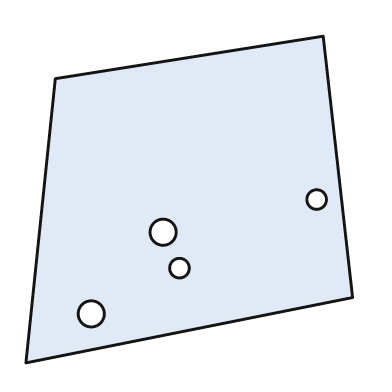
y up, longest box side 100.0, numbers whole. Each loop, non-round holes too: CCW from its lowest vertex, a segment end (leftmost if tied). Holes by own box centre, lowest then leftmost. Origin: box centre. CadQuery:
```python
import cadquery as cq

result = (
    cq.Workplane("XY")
    .moveTo(-50.0, -50.0)
    .lineTo(50.0, -30.0)
    .lineTo(41.0, 50.0)
    .lineTo(-41.0, 37.0)
    .close()
    .moveTo(-30.0, -35.0)
    .circle(4.0)
    .moveTo(-3.0, -21.0)
    .circle(3.0)
    .moveTo(-8.0, -10.0)
    .circle(4.0)
    .moveTo(39.0, 0.0)
    .circle(3.0)
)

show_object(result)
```